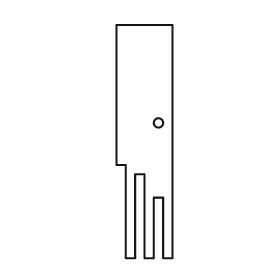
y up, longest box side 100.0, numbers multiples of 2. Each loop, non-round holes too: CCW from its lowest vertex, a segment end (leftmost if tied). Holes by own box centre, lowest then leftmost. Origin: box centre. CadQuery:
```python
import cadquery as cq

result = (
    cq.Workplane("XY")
    .moveTo(-8.0, -50.0)
    .lineTo(-4.0, -50.0)
    .lineTo(-4.0, -14.0)
    .lineTo(0.0, -14.0)
    .lineTo(0.0, -50.0)
    .lineTo(4.0, -50.0)
    .lineTo(4.0, -24.0)
    .lineTo(8.0, -24.0)
    .lineTo(8.0, -50.0)
    .lineTo(12.0, -50.0)
    .lineTo(12.0, 50.0)
    .lineTo(-12.0, 50.0)
    .lineTo(-12.0, -10.0)
    .lineTo(-8.0, -10.0)
    .close()
    .moveTo(6.0, 8.0)
    .circle(2.0)
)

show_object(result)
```